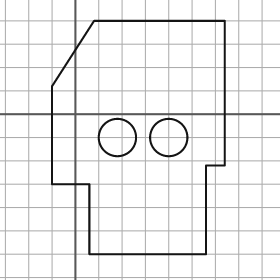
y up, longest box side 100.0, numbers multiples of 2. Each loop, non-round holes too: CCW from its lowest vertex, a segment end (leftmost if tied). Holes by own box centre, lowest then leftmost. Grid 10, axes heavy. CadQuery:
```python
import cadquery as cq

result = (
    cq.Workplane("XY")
    .moveTo(6.0, -60.0)
    .lineTo(56.0, -60.0)
    .lineTo(56.0, -22.0)
    .lineTo(64.0, -22.0)
    .lineTo(64.0, 40.0)
    .lineTo(8.0, 40.0)
    .lineTo(-10.0, 12.0)
    .lineTo(-10.0, -30.0)
    .lineTo(6.0, -30.0)
    .close()
    .moveTo(18.0, -10.0)
    .circle(8.0)
    .moveTo(40.0, -10.0)
    .circle(8.0)
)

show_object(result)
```